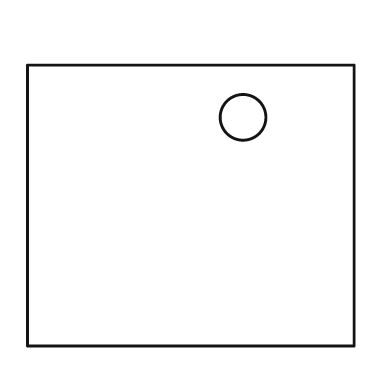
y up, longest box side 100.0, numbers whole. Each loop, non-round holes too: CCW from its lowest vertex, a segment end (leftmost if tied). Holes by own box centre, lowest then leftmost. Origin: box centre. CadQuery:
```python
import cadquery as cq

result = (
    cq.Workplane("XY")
    .moveTo(-50.0, -43.0)
    .lineTo(50.0, -43.0)
    .lineTo(50.0, 43.0)
    .lineTo(-50.0, 43.0)
    .close()
    .moveTo(16.0, 27.0)
    .circle(7.0)
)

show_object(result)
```